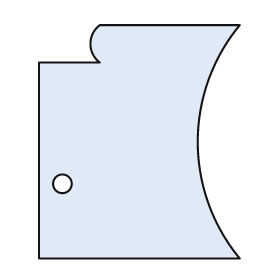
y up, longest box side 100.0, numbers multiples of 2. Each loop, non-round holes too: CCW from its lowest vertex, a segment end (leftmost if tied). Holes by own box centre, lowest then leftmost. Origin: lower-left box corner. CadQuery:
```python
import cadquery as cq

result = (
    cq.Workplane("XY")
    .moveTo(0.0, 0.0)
    .lineTo(86.0, 0.0)
    .threePointArc((68.0, 50.0), (86.0, 100.0))
    .lineTo(26.0, 100.0)
    .threePointArc((22.0, 92.0), (26.0, 84.0))
    .lineTo(0.0, 84.0)
    .close()
    .moveTo(10.0, 32.0)
    .circle(4.0)
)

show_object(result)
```